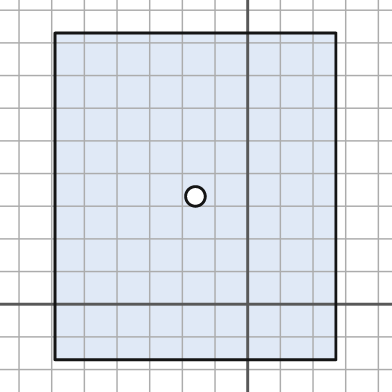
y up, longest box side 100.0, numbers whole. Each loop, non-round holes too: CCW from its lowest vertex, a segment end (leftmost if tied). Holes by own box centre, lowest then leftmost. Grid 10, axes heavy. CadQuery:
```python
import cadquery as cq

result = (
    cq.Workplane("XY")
    .moveTo(-59.0, -17.0)
    .lineTo(27.0, -17.0)
    .lineTo(27.0, 83.0)
    .lineTo(-59.0, 83.0)
    .close()
    .moveTo(-16.0, 33.0)
    .circle(3.0)
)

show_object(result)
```